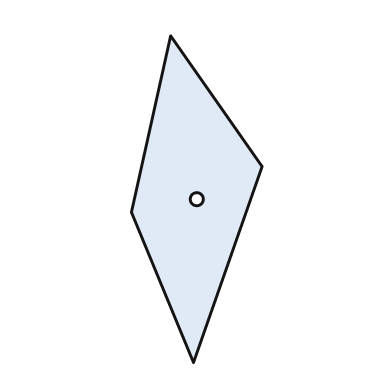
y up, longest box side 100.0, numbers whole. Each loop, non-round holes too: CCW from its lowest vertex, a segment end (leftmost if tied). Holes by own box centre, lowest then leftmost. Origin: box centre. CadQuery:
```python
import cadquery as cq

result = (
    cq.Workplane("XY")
    .moveTo(-1.0, -50.0)
    .lineTo(20.0, 10.0)
    .lineTo(-8.0, 50.0)
    .lineTo(-20.0, -4.0)
    .close()
    .moveTo(0.0, 0.0)
    .circle(2.0)
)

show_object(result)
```